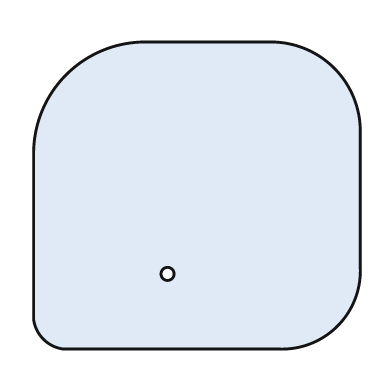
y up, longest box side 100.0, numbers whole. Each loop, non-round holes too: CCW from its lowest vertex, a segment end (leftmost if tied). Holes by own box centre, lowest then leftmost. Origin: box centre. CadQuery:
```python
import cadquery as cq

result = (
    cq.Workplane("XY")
    .moveTo(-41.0, -47.0)
    .lineTo(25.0, -47.0)
    .threePointArc((43.0, -40.0), (50.0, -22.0))
    .lineTo(50.0, 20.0)
    .threePointArc((42.0, 39.0), (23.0, 47.0))
    .lineTo(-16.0, 47.0)
    .threePointArc((-40.0, 37.0), (-50.0, 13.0))
    .lineTo(-50.0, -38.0)
    .threePointArc((-47.0, -44.0), (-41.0, -47.0))
    .close()
    .moveTo(-9.0, -24.0)
    .circle(2.0)
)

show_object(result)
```